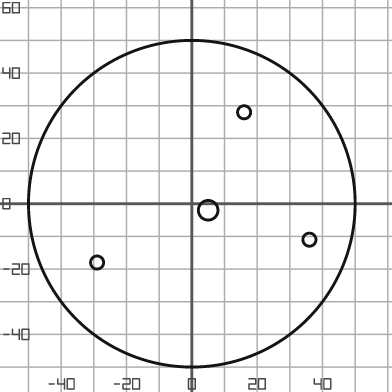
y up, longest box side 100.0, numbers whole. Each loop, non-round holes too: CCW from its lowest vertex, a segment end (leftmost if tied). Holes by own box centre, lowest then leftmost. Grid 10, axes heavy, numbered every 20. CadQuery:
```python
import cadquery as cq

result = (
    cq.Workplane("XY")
    .moveTo(0.0, 0.0)
    .circle(50.0)
    .moveTo(-29.0, -18.0)
    .circle(2.0)
    .moveTo(36.0, -11.0)
    .circle(2.0)
    .moveTo(5.0, -2.0)
    .circle(3.0)
    .moveTo(16.0, 28.0)
    .circle(2.0)
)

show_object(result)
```